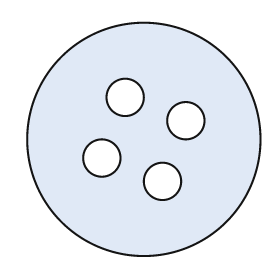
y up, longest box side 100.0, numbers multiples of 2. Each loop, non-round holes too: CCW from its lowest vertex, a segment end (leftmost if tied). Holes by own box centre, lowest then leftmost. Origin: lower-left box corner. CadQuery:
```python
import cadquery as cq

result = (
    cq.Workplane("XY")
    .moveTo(50.0, 50.0)
    .circle(50.0)
    .moveTo(58.0, 32.0)
    .circle(8.0)
    .moveTo(32.0, 42.0)
    .circle(8.0)
    .moveTo(68.0, 58.0)
    .circle(8.0)
    .moveTo(42.0, 68.0)
    .circle(8.0)
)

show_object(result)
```